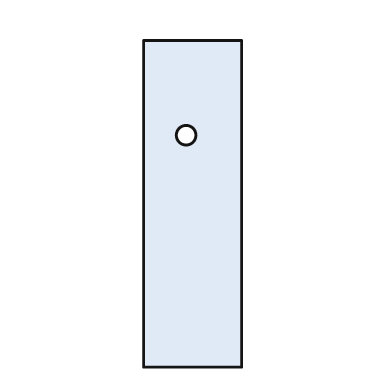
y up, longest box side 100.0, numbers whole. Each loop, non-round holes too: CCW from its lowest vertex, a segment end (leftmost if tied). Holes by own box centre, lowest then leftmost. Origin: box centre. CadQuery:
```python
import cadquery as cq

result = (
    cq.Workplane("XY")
    .moveTo(-15.0, -50.0)
    .lineTo(15.0, -50.0)
    .lineTo(15.0, 50.0)
    .lineTo(-15.0, 50.0)
    .close()
    .moveTo(-2.0, 21.0)
    .circle(3.0)
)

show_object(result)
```